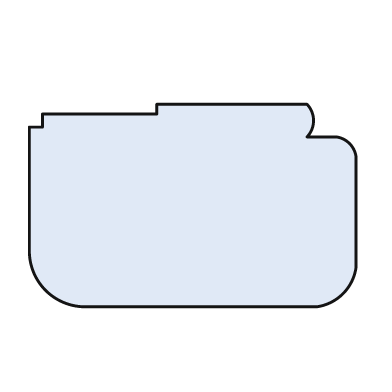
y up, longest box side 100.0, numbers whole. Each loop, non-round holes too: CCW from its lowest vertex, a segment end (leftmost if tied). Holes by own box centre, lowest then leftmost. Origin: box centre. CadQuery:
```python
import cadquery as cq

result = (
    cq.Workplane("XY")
    .moveTo(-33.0, -31.0)
    .lineTo(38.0, -31.0)
    .threePointArc((46.0, -27.0), (50.0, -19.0))
    .lineTo(50.0, 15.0)
    .threePointArc((48.0, 19.0), (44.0, 21.0))
    .lineTo(35.0, 21.0)
    .threePointArc((37.0, 26.0), (35.0, 31.0))
    .lineTo(-11.0, 31.0)
    .lineTo(-11.0, 28.0)
    .lineTo(-46.0, 28.0)
    .lineTo(-46.0, 24.0)
    .lineTo(-50.0, 24.0)
    .lineTo(-50.0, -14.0)
    .threePointArc((-45.0, -26.0), (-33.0, -31.0))
    .close()
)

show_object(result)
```